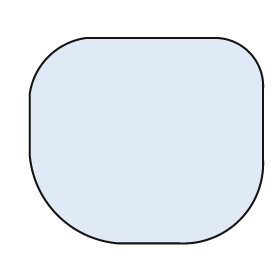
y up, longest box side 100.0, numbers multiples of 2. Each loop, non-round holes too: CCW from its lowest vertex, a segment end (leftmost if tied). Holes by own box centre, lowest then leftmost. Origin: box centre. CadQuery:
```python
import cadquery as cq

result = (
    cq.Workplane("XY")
    .moveTo(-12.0, -44.0)
    .lineTo(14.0, -44.0)
    .threePointArc((40.0, -34.0), (50.0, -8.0))
    .lineTo(50.0, 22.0)
    .threePointArc((44.0, 38.0), (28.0, 44.0))
    .lineTo(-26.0, 44.0)
    .threePointArc((-42.0, 36.0), (-50.0, 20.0))
    .lineTo(-50.0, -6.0)
    .threePointArc((-38.0, -32.0), (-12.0, -44.0))
    .close()
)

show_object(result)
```